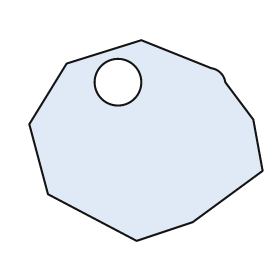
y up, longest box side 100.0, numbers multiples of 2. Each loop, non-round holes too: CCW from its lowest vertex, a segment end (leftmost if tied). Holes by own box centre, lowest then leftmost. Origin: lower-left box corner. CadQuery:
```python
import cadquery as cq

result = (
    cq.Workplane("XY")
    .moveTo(46.0, 0.0)
    .lineTo(70.0, 8.0)
    .lineTo(100.0, 30.0)
    .lineTo(96.0, 52.0)
    .lineTo(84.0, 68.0)
    .threePointArc((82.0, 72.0), (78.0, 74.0))
    .lineTo(48.0, 86.0)
    .lineTo(16.0, 76.0)
    .lineTo(0.0, 50.0)
    .lineTo(8.0, 20.0)
    .close()
    .moveTo(38.0, 68.0)
    .circle(10.0)
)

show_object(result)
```